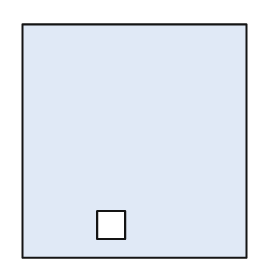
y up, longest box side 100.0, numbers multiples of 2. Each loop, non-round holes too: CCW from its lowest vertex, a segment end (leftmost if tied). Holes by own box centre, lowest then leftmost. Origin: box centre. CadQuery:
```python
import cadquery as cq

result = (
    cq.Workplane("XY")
    .moveTo(-48.0, -50.0)
    .lineTo(48.0, -50.0)
    .lineTo(48.0, 50.0)
    .lineTo(-48.0, 50.0)
    .close()
    .moveTo(-16.0, -42.0)
    .lineTo(-4.0, -42.0)
    .lineTo(-4.0, -30.0)
    .lineTo(-16.0, -30.0)
    .close()
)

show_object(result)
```